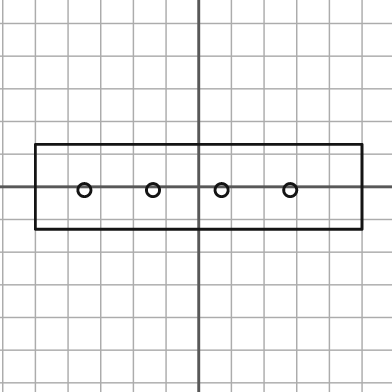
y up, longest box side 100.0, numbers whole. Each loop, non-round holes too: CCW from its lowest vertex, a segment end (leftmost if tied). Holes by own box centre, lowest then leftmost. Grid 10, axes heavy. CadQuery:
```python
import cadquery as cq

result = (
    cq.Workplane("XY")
    .moveTo(-50.0, -13.0)
    .lineTo(50.0, -13.0)
    .lineTo(50.0, 13.0)
    .lineTo(-50.0, 13.0)
    .close()
    .moveTo(-35.0, -1.0)
    .circle(2.0)
    .moveTo(-14.0, -1.0)
    .circle(2.0)
    .moveTo(7.0, -1.0)
    .circle(2.0)
    .moveTo(28.0, -1.0)
    .circle(2.0)
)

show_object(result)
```